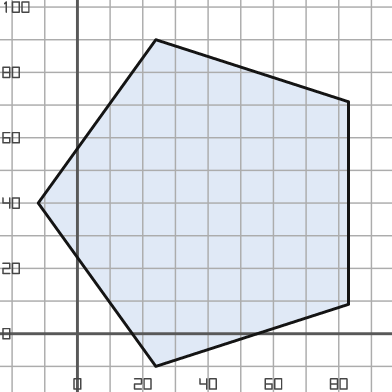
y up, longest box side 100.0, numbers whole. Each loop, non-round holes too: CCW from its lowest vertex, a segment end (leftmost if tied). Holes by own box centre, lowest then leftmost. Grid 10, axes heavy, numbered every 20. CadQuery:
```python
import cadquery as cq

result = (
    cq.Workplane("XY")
    .moveTo(24.0, -10.0)
    .lineTo(83.0, 9.0)
    .lineTo(83.0, 71.0)
    .lineTo(24.0, 90.0)
    .lineTo(-12.0, 40.0)
    .close()
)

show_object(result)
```